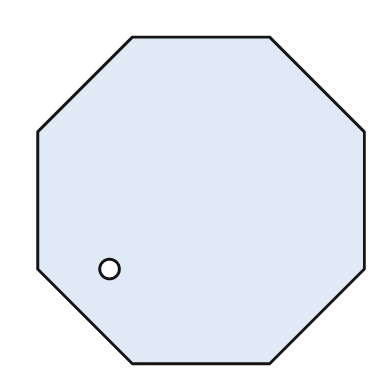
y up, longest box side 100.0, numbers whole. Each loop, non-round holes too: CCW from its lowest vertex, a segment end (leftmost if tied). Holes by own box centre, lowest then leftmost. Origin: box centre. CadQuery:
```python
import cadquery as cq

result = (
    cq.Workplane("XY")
    .moveTo(-21.0, -50.0)
    .lineTo(21.0, -50.0)
    .lineTo(50.0, -21.0)
    .lineTo(50.0, 21.0)
    .lineTo(21.0, 50.0)
    .lineTo(-21.0, 50.0)
    .lineTo(-50.0, 21.0)
    .lineTo(-50.0, -21.0)
    .close()
    .moveTo(-28.0, -21.0)
    .circle(3.0)
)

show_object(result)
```